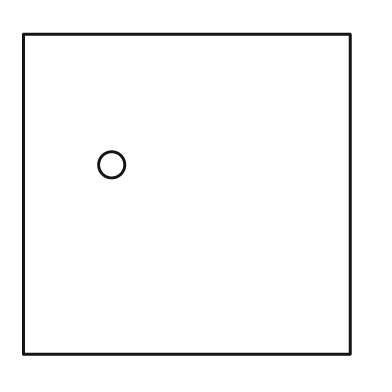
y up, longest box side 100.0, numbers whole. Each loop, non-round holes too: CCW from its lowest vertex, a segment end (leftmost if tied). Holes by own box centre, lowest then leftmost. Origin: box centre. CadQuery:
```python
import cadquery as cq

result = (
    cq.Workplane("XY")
    .moveTo(-50.0, -49.0)
    .lineTo(50.0, -49.0)
    .lineTo(50.0, 49.0)
    .lineTo(-50.0, 49.0)
    .close()
    .moveTo(-23.0, 9.0)
    .circle(4.0)
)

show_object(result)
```